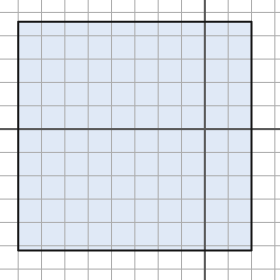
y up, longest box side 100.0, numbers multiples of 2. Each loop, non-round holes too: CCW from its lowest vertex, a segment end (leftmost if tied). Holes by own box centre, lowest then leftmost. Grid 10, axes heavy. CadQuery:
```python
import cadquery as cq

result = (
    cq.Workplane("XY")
    .moveTo(-80.0, -52.0)
    .lineTo(20.0, -52.0)
    .lineTo(20.0, 46.0)
    .lineTo(-80.0, 46.0)
    .close()
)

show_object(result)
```